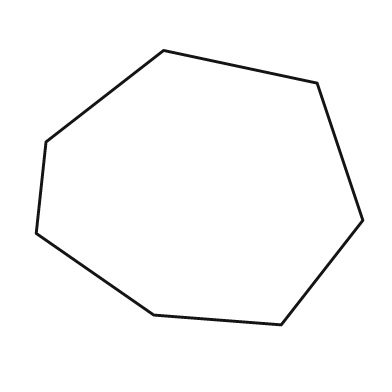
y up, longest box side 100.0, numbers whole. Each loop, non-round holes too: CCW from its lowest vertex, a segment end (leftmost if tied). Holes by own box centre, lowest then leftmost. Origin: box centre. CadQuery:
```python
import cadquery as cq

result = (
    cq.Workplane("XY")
    .moveTo(25.0, -42.0)
    .lineTo(50.0, -10.0)
    .lineTo(36.0, 32.0)
    .lineTo(-11.0, 42.0)
    .lineTo(-47.0, 14.0)
    .lineTo(-50.0, -14.0)
    .lineTo(-14.0, -39.0)
    .close()
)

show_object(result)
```